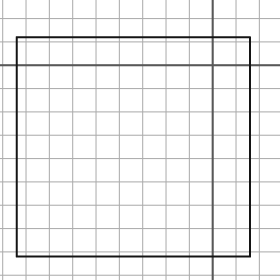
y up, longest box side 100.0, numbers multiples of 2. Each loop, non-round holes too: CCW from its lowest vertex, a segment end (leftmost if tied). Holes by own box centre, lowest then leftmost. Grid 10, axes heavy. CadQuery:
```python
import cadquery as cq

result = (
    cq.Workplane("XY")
    .moveTo(-84.0, -82.0)
    .lineTo(16.0, -82.0)
    .lineTo(16.0, 12.0)
    .lineTo(-84.0, 12.0)
    .close()
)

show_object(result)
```